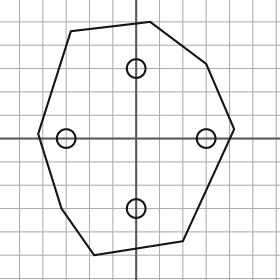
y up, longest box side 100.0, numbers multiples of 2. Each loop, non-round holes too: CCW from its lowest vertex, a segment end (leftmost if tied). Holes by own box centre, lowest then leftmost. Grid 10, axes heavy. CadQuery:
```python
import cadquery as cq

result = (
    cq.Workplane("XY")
    .moveTo(-18.0, -50.0)
    .lineTo(20.0, -44.0)
    .lineTo(42.0, 4.0)
    .lineTo(30.0, 32.0)
    .lineTo(6.0, 50.0)
    .lineTo(-28.0, 46.0)
    .lineTo(-42.0, 2.0)
    .lineTo(-32.0, -30.0)
    .close()
    .moveTo(0.0, -30.0)
    .circle(4.0)
    .moveTo(-30.0, 0.0)
    .circle(4.0)
    .moveTo(30.0, 0.0)
    .circle(4.0)
    .moveTo(0.0, 30.0)
    .circle(4.0)
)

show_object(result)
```